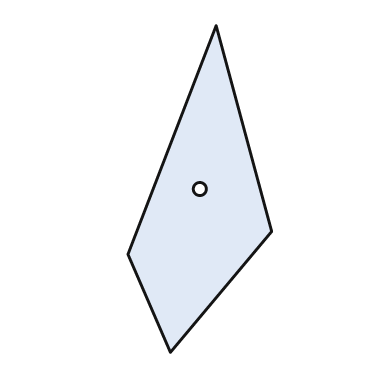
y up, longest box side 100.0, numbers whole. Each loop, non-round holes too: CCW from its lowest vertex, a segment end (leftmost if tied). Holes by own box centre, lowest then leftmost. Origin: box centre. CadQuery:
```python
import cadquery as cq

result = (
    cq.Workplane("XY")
    .moveTo(-9.0, -50.0)
    .lineTo(22.0, -13.0)
    .lineTo(5.0, 50.0)
    .lineTo(-22.0, -20.0)
    .close()
    .moveTo(0.0, 0.0)
    .circle(2.0)
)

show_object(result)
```